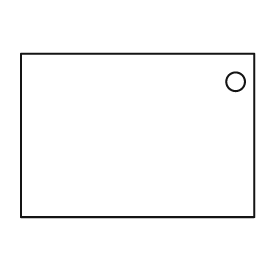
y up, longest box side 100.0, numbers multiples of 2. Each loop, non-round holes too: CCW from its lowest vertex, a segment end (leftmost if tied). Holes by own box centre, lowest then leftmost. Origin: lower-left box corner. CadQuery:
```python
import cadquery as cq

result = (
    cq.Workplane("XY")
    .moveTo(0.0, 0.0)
    .lineTo(100.0, 0.0)
    .lineTo(100.0, 70.0)
    .lineTo(0.0, 70.0)
    .close()
    .moveTo(92.0, 58.0)
    .circle(4.0)
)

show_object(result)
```